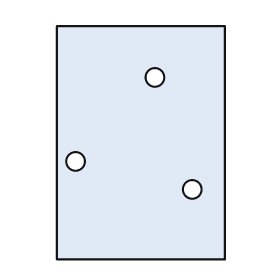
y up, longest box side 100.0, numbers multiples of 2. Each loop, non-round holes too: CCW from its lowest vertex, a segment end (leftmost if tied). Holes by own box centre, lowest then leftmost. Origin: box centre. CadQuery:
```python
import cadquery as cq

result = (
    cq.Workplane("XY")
    .moveTo(-36.0, -50.0)
    .lineTo(36.0, -50.0)
    .lineTo(36.0, 50.0)
    .lineTo(-36.0, 50.0)
    .close()
    .moveTo(22.0, -20.0)
    .circle(4.0)
    .moveTo(-28.0, -8.0)
    .circle(4.0)
    .moveTo(6.0, 28.0)
    .circle(4.0)
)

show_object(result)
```